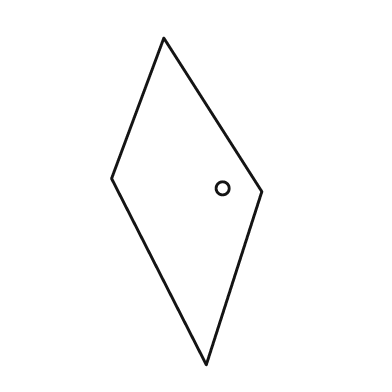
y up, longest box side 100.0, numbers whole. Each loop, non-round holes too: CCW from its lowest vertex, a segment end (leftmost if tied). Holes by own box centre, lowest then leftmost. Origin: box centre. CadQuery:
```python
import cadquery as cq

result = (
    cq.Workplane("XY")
    .moveTo(6.0, -50.0)
    .lineTo(23.0, 3.0)
    .lineTo(-7.0, 50.0)
    .lineTo(-23.0, 7.0)
    .close()
    .moveTo(11.0, 4.0)
    .circle(2.0)
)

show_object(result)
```